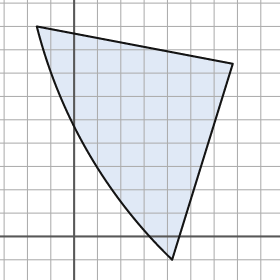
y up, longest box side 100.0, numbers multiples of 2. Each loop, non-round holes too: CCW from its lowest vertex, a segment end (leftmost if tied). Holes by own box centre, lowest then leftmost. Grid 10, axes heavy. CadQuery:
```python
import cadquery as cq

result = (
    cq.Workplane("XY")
    .moveTo(42.0, -10.0)
    .lineTo(68.0, 74.0)
    .lineTo(-16.0, 90.0)
    .threePointArc((6.0, 36.0), (42.0, -10.0))
    .close()
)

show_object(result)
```